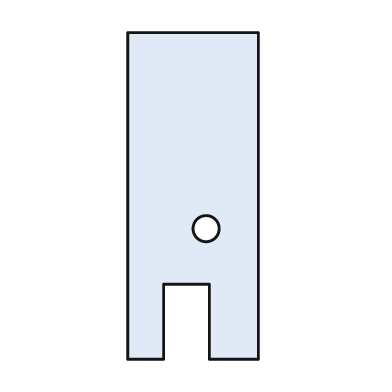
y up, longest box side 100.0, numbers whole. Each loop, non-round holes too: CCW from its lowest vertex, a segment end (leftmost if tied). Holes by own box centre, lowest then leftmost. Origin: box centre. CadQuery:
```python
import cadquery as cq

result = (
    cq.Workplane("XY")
    .moveTo(-20.0, -50.0)
    .lineTo(-9.0, -50.0)
    .lineTo(-9.0, -27.0)
    .lineTo(5.0, -27.0)
    .lineTo(5.0, -50.0)
    .lineTo(20.0, -50.0)
    .lineTo(20.0, 50.0)
    .lineTo(-20.0, 50.0)
    .close()
    .moveTo(4.0, -10.0)
    .circle(4.0)
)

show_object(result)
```